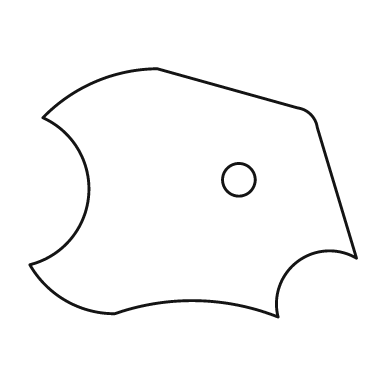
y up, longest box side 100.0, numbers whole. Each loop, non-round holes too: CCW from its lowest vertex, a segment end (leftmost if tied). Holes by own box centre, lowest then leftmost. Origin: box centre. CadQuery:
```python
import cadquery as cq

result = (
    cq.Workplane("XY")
    .moveTo(26.0, -38.0)
    .threePointArc((32.0, -21.0), (50.0, -20.0))
    .lineTo(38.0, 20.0)
    .threePointArc((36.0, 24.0), (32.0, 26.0))
    .lineTo(-11.0, 38.0)
    .threePointArc((-30.0, 34.0), (-46.0, 23.0))
    .threePointArc((-32.0, -1.0), (-50.0, -22.0))
    .threePointArc((-39.0, -33.0), (-24.0, -37.0))
    .threePointArc((1.0, -33.0), (26.0, -38.0))
    .close()
    .moveTo(14.0, 4.0)
    .circle(5.0)
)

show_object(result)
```